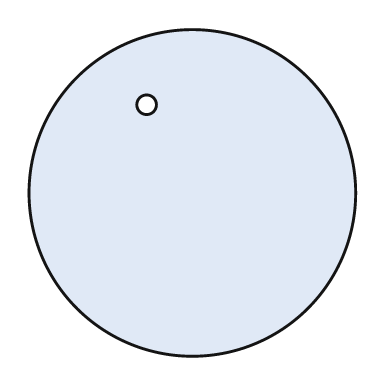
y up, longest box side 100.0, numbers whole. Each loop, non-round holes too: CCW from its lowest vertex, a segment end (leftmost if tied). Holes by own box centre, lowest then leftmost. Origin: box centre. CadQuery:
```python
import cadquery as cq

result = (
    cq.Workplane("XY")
    .moveTo(0.0, 0.0)
    .circle(50.0)
    .moveTo(-14.0, 27.0)
    .circle(3.0)
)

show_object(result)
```